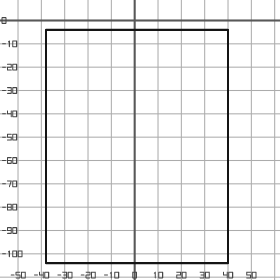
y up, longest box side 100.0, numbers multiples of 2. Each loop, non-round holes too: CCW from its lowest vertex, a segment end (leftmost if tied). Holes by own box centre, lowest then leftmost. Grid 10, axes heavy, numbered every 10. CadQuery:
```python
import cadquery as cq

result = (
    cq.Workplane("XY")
    .moveTo(-38.0, -104.0)
    .lineTo(40.0, -104.0)
    .lineTo(40.0, -4.0)
    .lineTo(-38.0, -4.0)
    .close()
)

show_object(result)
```